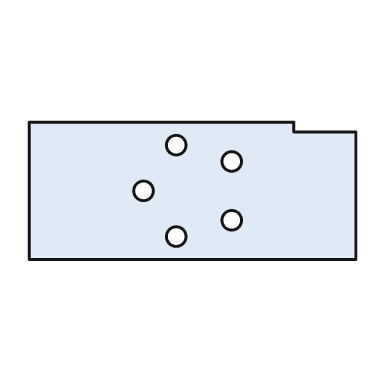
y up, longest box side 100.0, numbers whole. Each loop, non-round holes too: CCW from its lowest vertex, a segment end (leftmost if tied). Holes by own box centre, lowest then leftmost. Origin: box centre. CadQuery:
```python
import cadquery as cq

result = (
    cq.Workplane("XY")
    .moveTo(-50.0, -21.0)
    .lineTo(50.0, -21.0)
    .lineTo(50.0, 18.0)
    .lineTo(31.0, 18.0)
    .lineTo(31.0, 21.0)
    .lineTo(-50.0, 21.0)
    .close()
    .moveTo(-5.0, -14.0)
    .circle(3.0)
    .moveTo(12.0, -9.0)
    .circle(3.0)
    .moveTo(-15.0, 0.0)
    .circle(3.0)
    .moveTo(12.0, 9.0)
    .circle(3.0)
    .moveTo(-5.0, 14.0)
    .circle(3.0)
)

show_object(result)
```